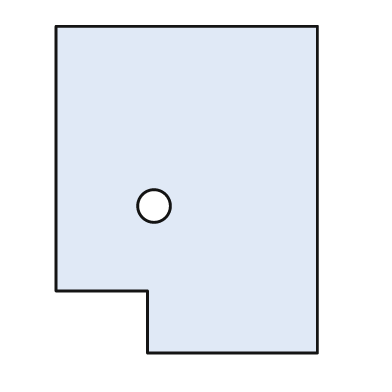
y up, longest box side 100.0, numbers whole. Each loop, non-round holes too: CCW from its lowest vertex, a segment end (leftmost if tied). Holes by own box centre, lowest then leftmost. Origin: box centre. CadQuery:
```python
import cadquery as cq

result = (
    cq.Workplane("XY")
    .moveTo(-12.0, -50.0)
    .lineTo(40.0, -50.0)
    .lineTo(40.0, 50.0)
    .lineTo(-40.0, 50.0)
    .lineTo(-40.0, -31.0)
    .lineTo(-12.0, -31.0)
    .close()
    .moveTo(-10.0, -5.0)
    .circle(5.0)
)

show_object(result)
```